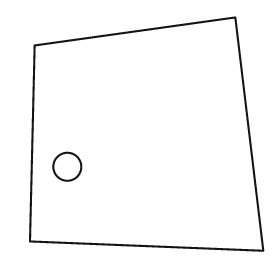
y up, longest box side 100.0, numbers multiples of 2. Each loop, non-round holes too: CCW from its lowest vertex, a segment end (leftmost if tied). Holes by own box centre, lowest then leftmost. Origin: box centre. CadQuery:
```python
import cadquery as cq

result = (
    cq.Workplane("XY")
    .moveTo(50.0, -50.0)
    .lineTo(38.0, 50.0)
    .lineTo(-48.0, 38.0)
    .lineTo(-50.0, -46.0)
    .close()
    .moveTo(-34.0, -14.0)
    .circle(6.0)
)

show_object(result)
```